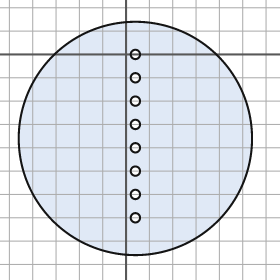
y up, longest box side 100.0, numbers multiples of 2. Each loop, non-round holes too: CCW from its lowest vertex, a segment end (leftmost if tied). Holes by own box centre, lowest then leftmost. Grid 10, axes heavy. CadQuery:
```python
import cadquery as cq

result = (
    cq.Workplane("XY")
    .moveTo(4.0, -36.0)
    .circle(50.0)
    .moveTo(4.0, -70.0)
    .circle(2.0)
    .moveTo(4.0, -60.0)
    .circle(2.0)
    .moveTo(4.0, -50.0)
    .circle(2.0)
    .moveTo(4.0, -40.0)
    .circle(2.0)
    .moveTo(4.0, -30.0)
    .circle(2.0)
    .moveTo(4.0, -20.0)
    .circle(2.0)
    .moveTo(4.0, -10.0)
    .circle(2.0)
    .moveTo(4.0, 0.0)
    .circle(2.0)
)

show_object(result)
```